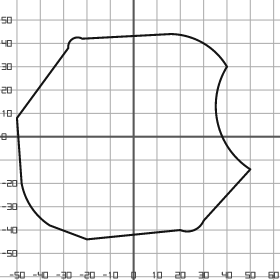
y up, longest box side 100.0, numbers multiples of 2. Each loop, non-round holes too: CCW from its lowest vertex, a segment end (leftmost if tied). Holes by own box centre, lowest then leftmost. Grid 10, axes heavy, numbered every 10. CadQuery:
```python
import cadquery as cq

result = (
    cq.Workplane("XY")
    .moveTo(-20.0, -44.0)
    .lineTo(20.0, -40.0)
    .threePointArc((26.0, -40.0), (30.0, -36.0))
    .lineTo(50.0, -14.0)
    .threePointArc((36.0, 6.0), (40.0, 30.0))
    .threePointArc((30.0, 40.0), (16.0, 44.0))
    .lineTo(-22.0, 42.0)
    .threePointArc((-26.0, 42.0), (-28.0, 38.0))
    .lineTo(-50.0, 8.0)
    .lineTo(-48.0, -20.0)
    .threePointArc((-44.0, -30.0), (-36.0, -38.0))
    .close()
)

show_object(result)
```